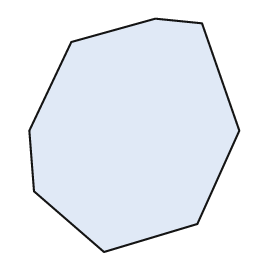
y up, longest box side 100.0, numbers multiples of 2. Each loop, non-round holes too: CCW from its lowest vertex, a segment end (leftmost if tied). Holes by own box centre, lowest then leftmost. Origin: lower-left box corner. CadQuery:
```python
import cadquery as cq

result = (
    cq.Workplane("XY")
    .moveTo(32.0, 0.0)
    .lineTo(72.0, 12.0)
    .lineTo(90.0, 52.0)
    .lineTo(74.0, 98.0)
    .lineTo(54.0, 100.0)
    .lineTo(18.0, 90.0)
    .lineTo(0.0, 52.0)
    .lineTo(2.0, 26.0)
    .close()
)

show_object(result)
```